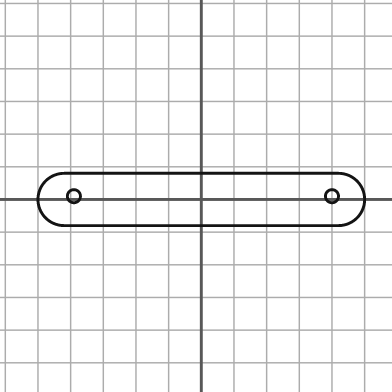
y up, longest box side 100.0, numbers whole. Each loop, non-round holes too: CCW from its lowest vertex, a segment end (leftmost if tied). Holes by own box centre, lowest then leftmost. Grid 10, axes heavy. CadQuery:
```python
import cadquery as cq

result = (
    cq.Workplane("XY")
    .moveTo(-42.0, -8.0)
    .lineTo(42.0, -8.0)
    .threePointArc((50.0, 0.0), (42.0, 8.0))
    .lineTo(-42.0, 8.0)
    .threePointArc((-50.0, 0.0), (-42.0, -8.0))
    .close()
    .moveTo(-39.0, 1.0)
    .circle(2.0)
    .moveTo(40.0, 1.0)
    .circle(2.0)
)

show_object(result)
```